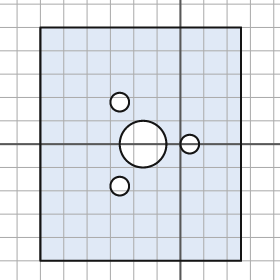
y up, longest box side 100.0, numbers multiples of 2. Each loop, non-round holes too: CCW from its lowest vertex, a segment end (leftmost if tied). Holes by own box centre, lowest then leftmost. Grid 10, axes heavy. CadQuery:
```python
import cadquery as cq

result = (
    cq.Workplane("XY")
    .moveTo(-60.0, -50.0)
    .lineTo(26.0, -50.0)
    .lineTo(26.0, 50.0)
    .lineTo(-60.0, 50.0)
    .close()
    .moveTo(-26.0, -18.0)
    .circle(4.0)
    .moveTo(-16.0, 0.0)
    .circle(10.0)
    .moveTo(4.0, 0.0)
    .circle(4.0)
    .moveTo(-26.0, 18.0)
    .circle(4.0)
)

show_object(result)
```